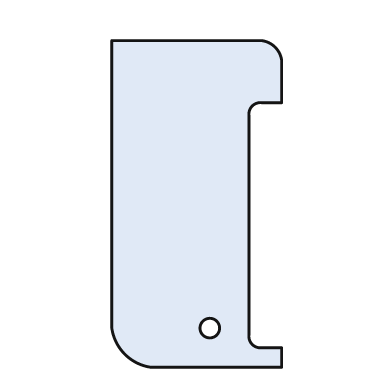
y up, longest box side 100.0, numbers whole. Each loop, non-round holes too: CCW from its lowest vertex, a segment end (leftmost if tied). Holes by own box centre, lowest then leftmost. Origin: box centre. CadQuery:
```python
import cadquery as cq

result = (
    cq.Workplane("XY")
    .moveTo(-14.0, -50.0)
    .lineTo(26.0, -50.0)
    .lineTo(26.0, -44.0)
    .lineTo(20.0, -44.0)
    .threePointArc((17.0, -43.0), (16.0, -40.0))
    .lineTo(16.0, 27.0)
    .threePointArc((17.0, 30.0), (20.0, 31.0))
    .lineTo(26.0, 31.0)
    .lineTo(26.0, 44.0)
    .threePointArc((24.0, 48.0), (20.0, 50.0))
    .lineTo(-26.0, 50.0)
    .lineTo(-26.0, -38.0)
    .threePointArc((-22.0, -46.0), (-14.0, -50.0))
    .close()
    .moveTo(4.0, -38.0)
    .circle(3.0)
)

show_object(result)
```